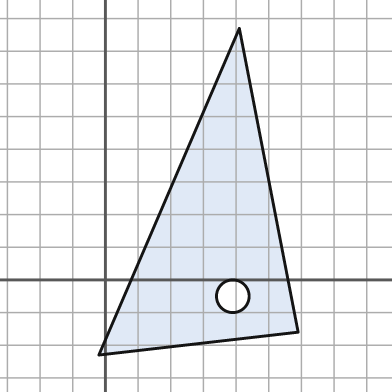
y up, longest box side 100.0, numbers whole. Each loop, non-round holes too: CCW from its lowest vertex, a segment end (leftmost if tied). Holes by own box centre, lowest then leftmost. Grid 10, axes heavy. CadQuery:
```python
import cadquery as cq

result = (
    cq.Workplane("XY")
    .moveTo(-2.0, -23.0)
    .lineTo(59.0, -16.0)
    .lineTo(41.0, 77.0)
    .close()
    .moveTo(39.0, -5.0)
    .circle(5.0)
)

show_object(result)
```